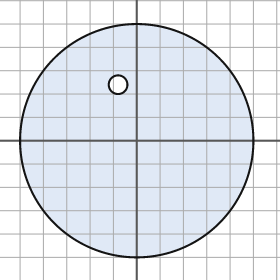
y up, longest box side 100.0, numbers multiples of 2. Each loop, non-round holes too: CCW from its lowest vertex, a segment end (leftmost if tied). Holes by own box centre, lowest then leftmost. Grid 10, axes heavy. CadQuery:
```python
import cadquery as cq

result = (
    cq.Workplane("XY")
    .moveTo(0.0, 0.0)
    .circle(50.0)
    .moveTo(-8.0, 24.0)
    .circle(4.0)
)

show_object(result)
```